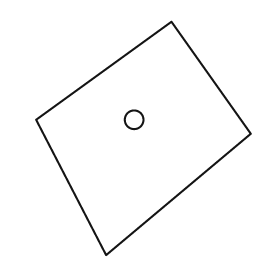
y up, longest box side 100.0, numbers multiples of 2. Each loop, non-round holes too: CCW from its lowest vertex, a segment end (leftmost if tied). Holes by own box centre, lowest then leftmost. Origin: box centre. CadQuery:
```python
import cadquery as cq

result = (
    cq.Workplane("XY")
    .moveTo(-16.0, -50.0)
    .lineTo(46.0, 2.0)
    .lineTo(12.0, 50.0)
    .lineTo(-46.0, 8.0)
    .close()
    .moveTo(-4.0, 8.0)
    .circle(4.0)
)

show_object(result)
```